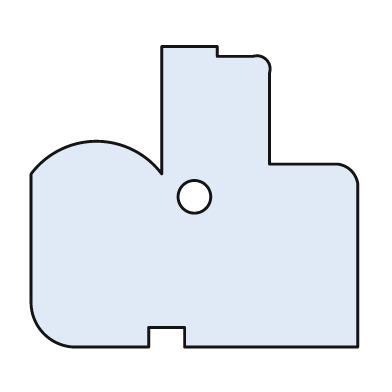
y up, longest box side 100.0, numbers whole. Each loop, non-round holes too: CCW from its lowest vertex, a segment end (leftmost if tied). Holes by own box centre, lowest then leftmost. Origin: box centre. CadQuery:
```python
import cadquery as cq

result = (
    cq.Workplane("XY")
    .moveTo(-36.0, -46.0)
    .lineTo(-14.0, -46.0)
    .lineTo(-14.0, -40.0)
    .lineTo(-3.0, -40.0)
    .lineTo(-3.0, -46.0)
    .lineTo(50.0, -46.0)
    .lineTo(50.0, 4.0)
    .threePointArc((48.0, 8.0), (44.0, 10.0))
    .lineTo(23.0, 10.0)
    .lineTo(23.0, 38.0)
    .threePointArc((22.0, 42.0), (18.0, 43.0))
    .lineTo(7.0, 43.0)
    .lineTo(7.0, 46.0)
    .lineTo(-10.0, 46.0)
    .lineTo(-10.0, 7.0)
    .threePointArc((-30.0, 17.0), (-50.0, 7.0))
    .lineTo(-50.0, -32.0)
    .threePointArc((-46.0, -42.0), (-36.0, -46.0))
    .close()
    .moveTo(0.0, 0.0)
    .circle(5.0)
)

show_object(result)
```